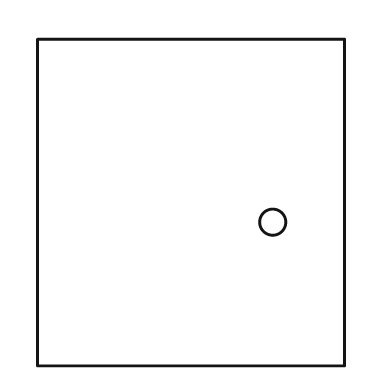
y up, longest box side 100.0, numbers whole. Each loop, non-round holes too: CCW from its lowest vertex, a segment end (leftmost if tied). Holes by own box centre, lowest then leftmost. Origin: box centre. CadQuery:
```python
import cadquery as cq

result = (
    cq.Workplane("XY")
    .moveTo(-47.0, -50.0)
    .lineTo(47.0, -50.0)
    .lineTo(47.0, 50.0)
    .lineTo(-47.0, 50.0)
    .close()
    .moveTo(25.0, -6.0)
    .circle(4.0)
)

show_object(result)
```